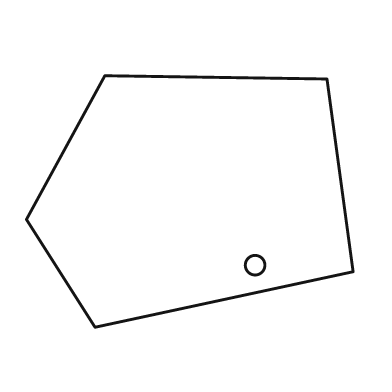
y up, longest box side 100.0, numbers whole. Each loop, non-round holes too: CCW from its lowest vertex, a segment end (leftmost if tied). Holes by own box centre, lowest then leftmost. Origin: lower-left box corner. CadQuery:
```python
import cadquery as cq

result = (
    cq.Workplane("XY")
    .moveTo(21.0, 0.0)
    .lineTo(100.0, 17.0)
    .lineTo(92.0, 76.0)
    .lineTo(24.0, 77.0)
    .lineTo(0.0, 33.0)
    .close()
    .moveTo(70.0, 19.0)
    .circle(3.0)
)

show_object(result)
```